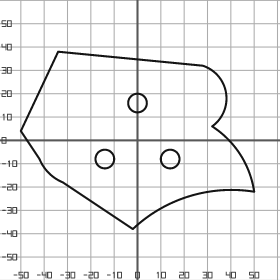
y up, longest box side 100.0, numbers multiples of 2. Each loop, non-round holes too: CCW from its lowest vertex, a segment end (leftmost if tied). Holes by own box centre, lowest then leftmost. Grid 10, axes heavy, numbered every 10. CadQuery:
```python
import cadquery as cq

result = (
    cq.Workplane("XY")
    .moveTo(-2.0, -38.0)
    .threePointArc((22.0, -24.0), (50.0, -22.0))
    .threePointArc((44.0, -6.0), (32.0, 6.0))
    .threePointArc((38.0, 20.0), (28.0, 32.0))
    .lineTo(-34.0, 38.0)
    .lineTo(-50.0, 4.0)
    .lineTo(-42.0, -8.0)
    .threePointArc((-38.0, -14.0), (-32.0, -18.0))
    .close()
    .moveTo(-14.0, -8.0)
    .circle(4.0)
    .moveTo(14.0, -8.0)
    .circle(4.0)
    .moveTo(0.0, 16.0)
    .circle(4.0)
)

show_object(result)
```